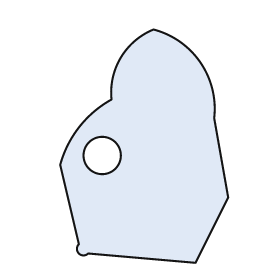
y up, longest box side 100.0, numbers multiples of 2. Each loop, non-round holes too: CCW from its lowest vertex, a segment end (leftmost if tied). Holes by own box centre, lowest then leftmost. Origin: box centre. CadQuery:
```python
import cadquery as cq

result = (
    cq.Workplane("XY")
    .moveTo(22.0, -50.0)
    .lineTo(36.0, -22.0)
    .lineTo(30.0, 12.0)
    .threePointArc((24.0, 36.0), (4.0, 50.0))
    .threePointArc((-10.0, 38.0), (-14.0, 20.0))
    .threePointArc((-28.0, 8.0), (-36.0, -8.0))
    .lineTo(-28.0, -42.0)
    .threePointArc((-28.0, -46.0), (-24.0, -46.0))
    .close()
    .moveTo(-18.0, -4.0)
    .circle(8.0)
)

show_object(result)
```